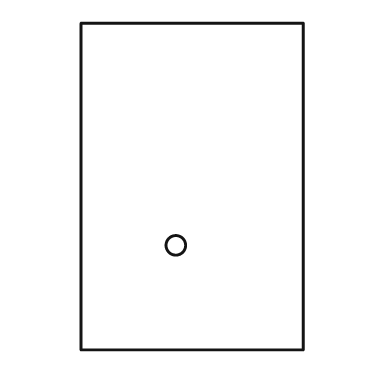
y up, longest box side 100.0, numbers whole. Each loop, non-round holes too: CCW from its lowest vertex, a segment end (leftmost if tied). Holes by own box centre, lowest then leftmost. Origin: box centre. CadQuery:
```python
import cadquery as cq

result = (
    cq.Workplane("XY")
    .moveTo(-34.0, -50.0)
    .lineTo(34.0, -50.0)
    .lineTo(34.0, 50.0)
    .lineTo(-34.0, 50.0)
    .close()
    .moveTo(-5.0, -18.0)
    .circle(3.0)
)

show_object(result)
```